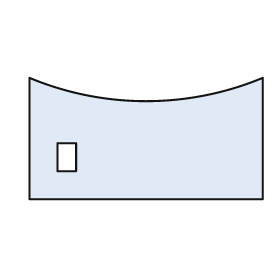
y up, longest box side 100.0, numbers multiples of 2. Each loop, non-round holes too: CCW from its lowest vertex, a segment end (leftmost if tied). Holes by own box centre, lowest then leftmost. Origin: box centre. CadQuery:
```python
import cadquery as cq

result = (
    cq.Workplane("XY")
    .moveTo(-50.0, -26.0)
    .lineTo(50.0, -26.0)
    .lineTo(50.0, 26.0)
    .threePointArc((0.0, 16.0), (-50.0, 26.0))
    .close()
    .moveTo(-38.0, -14.0)
    .lineTo(-30.0, -14.0)
    .lineTo(-30.0, -2.0)
    .lineTo(-38.0, -2.0)
    .close()
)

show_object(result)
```